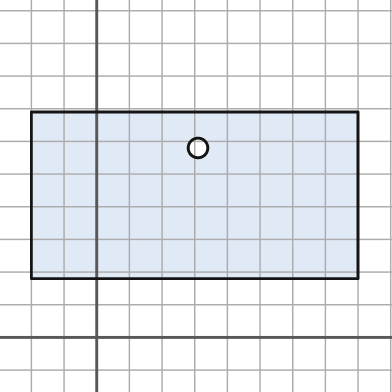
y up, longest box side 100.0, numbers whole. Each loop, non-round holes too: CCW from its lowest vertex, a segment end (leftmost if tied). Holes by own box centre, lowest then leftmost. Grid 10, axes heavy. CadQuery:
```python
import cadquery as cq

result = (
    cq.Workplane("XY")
    .moveTo(-20.0, 18.0)
    .lineTo(80.0, 18.0)
    .lineTo(80.0, 69.0)
    .lineTo(-20.0, 69.0)
    .close()
    .moveTo(31.0, 58.0)
    .circle(3.0)
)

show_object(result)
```